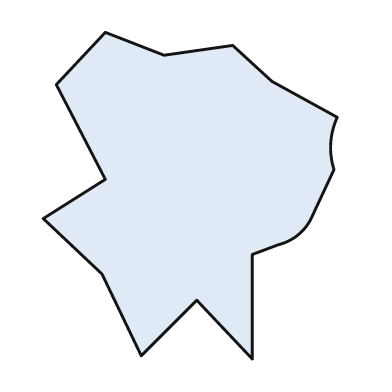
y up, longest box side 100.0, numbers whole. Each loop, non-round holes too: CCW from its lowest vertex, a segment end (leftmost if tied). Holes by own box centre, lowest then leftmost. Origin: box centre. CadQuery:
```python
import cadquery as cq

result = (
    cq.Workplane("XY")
    .moveTo(19.0, -50.0)
    .lineTo(19.0, -18.0)
    .lineTo(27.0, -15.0)
    .threePointArc((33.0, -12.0), (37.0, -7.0))
    .lineTo(44.0, 8.0)
    .threePointArc((43.0, 16.0), (45.0, 24.0))
    .lineTo(25.0, 35.0)
    .lineTo(13.0, 46.0)
    .lineTo(-8.0, 43.0)
    .lineTo(-26.0, 50.0)
    .lineTo(-41.0, 34.0)
    .lineTo(-26.0, 5.0)
    .lineTo(-45.0, -7.0)
    .lineTo(-27.0, -24.0)
    .lineTo(-15.0, -49.0)
    .lineTo(2.0, -32.0)
    .close()
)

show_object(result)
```